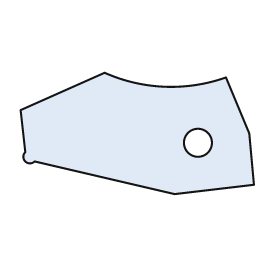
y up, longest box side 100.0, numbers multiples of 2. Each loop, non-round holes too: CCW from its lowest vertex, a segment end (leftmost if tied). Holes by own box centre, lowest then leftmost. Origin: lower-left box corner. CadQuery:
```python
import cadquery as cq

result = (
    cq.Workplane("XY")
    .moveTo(66.0, 0.0)
    .lineTo(100.0, 4.0)
    .lineTo(98.0, 26.0)
    .lineTo(88.0, 50.0)
    .threePointArc((62.0, 46.0), (36.0, 52.0))
    .lineTo(0.0, 36.0)
    .lineTo(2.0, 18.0)
    .threePointArc((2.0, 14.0), (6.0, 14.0))
    .close()
    .moveTo(76.0, 22.0)
    .circle(6.0)
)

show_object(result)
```